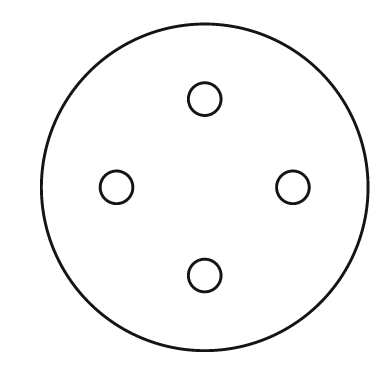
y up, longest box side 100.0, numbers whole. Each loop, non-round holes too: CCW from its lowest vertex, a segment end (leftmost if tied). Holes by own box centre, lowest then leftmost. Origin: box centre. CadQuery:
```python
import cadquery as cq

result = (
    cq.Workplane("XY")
    .moveTo(0.0, 0.0)
    .circle(50.0)
    .moveTo(0.0, -27.0)
    .circle(5.0)
    .moveTo(-27.0, 0.0)
    .circle(5.0)
    .moveTo(27.0, 0.0)
    .circle(5.0)
    .moveTo(0.0, 27.0)
    .circle(5.0)
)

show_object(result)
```